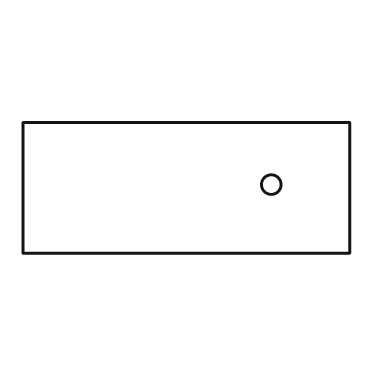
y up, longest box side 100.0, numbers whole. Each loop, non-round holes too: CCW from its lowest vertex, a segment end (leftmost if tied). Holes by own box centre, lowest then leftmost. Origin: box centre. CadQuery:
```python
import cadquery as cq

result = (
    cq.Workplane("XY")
    .moveTo(-50.0, -20.0)
    .lineTo(50.0, -20.0)
    .lineTo(50.0, 20.0)
    .lineTo(-50.0, 20.0)
    .close()
    .moveTo(26.0, 1.0)
    .circle(3.0)
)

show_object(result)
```